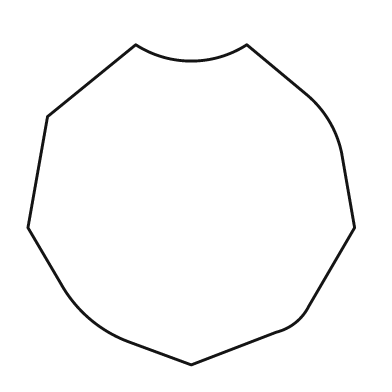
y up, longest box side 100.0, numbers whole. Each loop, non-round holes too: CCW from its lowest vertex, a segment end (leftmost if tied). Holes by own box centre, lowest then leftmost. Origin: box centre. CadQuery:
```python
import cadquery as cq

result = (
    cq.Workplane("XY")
    .moveTo(0.0, -49.0)
    .lineTo(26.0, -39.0)
    .threePointArc((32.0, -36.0), (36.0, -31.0))
    .lineTo(50.0, -7.0)
    .lineTo(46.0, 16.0)
    .threePointArc((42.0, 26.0), (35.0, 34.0))
    .lineTo(17.0, 49.0)
    .threePointArc((0.0, 44.0), (-17.0, 49.0))
    .lineTo(-44.0, 27.0)
    .lineTo(-50.0, -7.0)
    .lineTo(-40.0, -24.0)
    .threePointArc((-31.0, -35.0), (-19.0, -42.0))
    .close()
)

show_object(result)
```